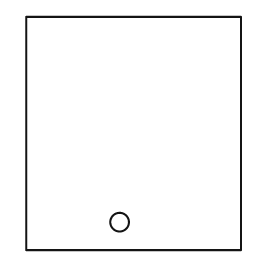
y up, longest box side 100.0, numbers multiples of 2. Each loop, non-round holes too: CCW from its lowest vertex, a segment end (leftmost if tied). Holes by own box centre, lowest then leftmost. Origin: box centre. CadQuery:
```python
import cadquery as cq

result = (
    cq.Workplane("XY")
    .moveTo(-46.0, -50.0)
    .lineTo(46.0, -50.0)
    .lineTo(46.0, 50.0)
    .lineTo(-46.0, 50.0)
    .close()
    .moveTo(-6.0, -38.0)
    .circle(4.0)
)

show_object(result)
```